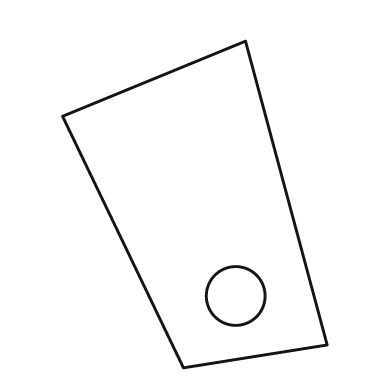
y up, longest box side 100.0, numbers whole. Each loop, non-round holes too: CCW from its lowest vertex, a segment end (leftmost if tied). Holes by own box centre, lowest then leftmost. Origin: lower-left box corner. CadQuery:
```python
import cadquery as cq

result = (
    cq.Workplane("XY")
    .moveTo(37.0, 0.0)
    .lineTo(81.0, 7.0)
    .lineTo(56.0, 100.0)
    .lineTo(0.0, 77.0)
    .close()
    .moveTo(53.0, 22.0)
    .circle(9.0)
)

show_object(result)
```